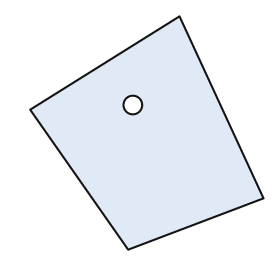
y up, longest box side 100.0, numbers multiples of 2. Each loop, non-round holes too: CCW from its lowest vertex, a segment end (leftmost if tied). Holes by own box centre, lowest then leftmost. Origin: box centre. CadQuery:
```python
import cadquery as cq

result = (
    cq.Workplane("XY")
    .moveTo(-8.0, -50.0)
    .lineTo(50.0, -28.0)
    .lineTo(14.0, 50.0)
    .lineTo(-50.0, 10.0)
    .close()
    .moveTo(-6.0, 12.0)
    .circle(4.0)
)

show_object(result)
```